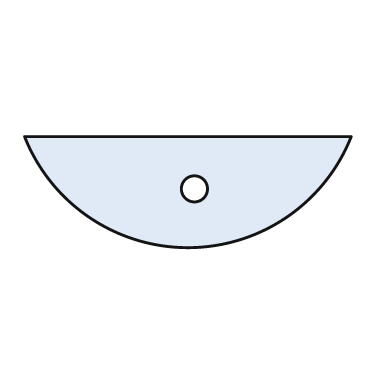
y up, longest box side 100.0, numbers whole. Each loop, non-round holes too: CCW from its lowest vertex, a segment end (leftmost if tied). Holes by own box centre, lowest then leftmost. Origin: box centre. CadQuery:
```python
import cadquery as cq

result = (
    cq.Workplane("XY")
    .moveTo(-50.0, 17.0)
    .threePointArc((0.0, -17.0), (50.0, 17.0))
    .close()
    .moveTo(2.0, 1.0)
    .circle(4.0)
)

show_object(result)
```